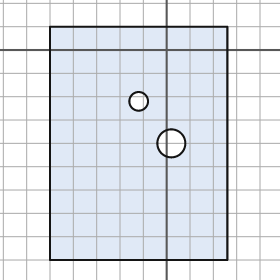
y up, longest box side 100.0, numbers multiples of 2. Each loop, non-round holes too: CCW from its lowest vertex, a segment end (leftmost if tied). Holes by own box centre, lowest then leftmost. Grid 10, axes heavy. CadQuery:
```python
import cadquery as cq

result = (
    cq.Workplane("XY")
    .moveTo(-50.0, -90.0)
    .lineTo(26.0, -90.0)
    .lineTo(26.0, 10.0)
    .lineTo(-50.0, 10.0)
    .close()
    .moveTo(2.0, -40.0)
    .circle(6.0)
    .moveTo(-12.0, -22.0)
    .circle(4.0)
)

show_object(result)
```